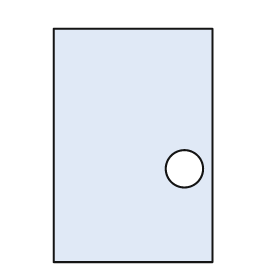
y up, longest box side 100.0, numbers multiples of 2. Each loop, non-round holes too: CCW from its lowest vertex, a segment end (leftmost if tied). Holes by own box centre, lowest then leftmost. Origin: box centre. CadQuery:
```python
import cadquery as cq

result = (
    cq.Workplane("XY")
    .moveTo(-34.0, -50.0)
    .lineTo(34.0, -50.0)
    .lineTo(34.0, 50.0)
    .lineTo(-34.0, 50.0)
    .close()
    .moveTo(22.0, -10.0)
    .circle(8.0)
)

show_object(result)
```